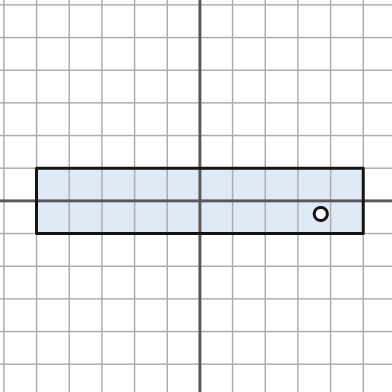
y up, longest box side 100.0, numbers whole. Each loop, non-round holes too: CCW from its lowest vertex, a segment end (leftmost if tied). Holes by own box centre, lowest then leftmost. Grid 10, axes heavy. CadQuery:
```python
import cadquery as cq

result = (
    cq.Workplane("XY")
    .moveTo(-50.0, -10.0)
    .lineTo(50.0, -10.0)
    .lineTo(50.0, 10.0)
    .lineTo(-50.0, 10.0)
    .close()
    .moveTo(37.0, -4.0)
    .circle(2.0)
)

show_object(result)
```